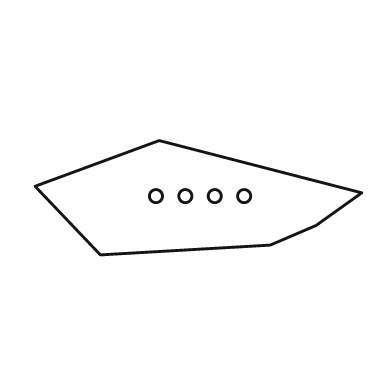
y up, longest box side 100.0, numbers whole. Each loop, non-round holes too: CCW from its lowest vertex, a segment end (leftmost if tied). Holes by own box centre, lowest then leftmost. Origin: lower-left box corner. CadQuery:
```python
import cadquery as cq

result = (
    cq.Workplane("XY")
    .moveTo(20.0, 0.0)
    .lineTo(72.0, 3.0)
    .lineTo(86.0, 9.0)
    .lineTo(100.0, 19.0)
    .lineTo(38.0, 35.0)
    .lineTo(0.0, 21.0)
    .close()
    .moveTo(37.0, 18.0)
    .circle(2.0)
    .moveTo(46.0, 18.0)
    .circle(2.0)
    .moveTo(55.0, 18.0)
    .circle(2.0)
    .moveTo(64.0, 18.0)
    .circle(2.0)
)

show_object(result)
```